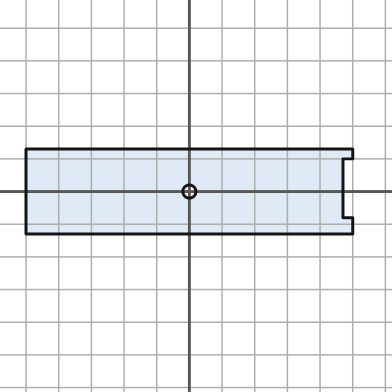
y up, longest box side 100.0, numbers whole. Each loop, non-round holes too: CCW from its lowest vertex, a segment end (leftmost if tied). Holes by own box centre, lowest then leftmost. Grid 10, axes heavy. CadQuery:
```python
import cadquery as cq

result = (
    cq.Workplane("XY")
    .moveTo(-50.0, -13.0)
    .lineTo(50.0, -13.0)
    .lineTo(50.0, -8.0)
    .lineTo(47.0, -8.0)
    .lineTo(47.0, 10.0)
    .lineTo(50.0, 10.0)
    .lineTo(50.0, 13.0)
    .lineTo(-50.0, 13.0)
    .close()
    .moveTo(0.0, 0.0)
    .circle(2.0)
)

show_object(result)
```